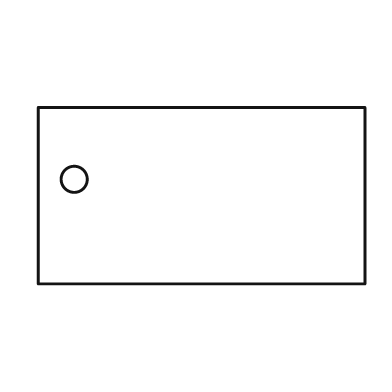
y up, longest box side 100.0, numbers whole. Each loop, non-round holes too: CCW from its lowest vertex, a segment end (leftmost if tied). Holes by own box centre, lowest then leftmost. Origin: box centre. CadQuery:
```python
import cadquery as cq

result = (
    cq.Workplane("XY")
    .moveTo(-50.0, -27.0)
    .lineTo(50.0, -27.0)
    .lineTo(50.0, 27.0)
    .lineTo(-50.0, 27.0)
    .close()
    .moveTo(-39.0, 5.0)
    .circle(4.0)
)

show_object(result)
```